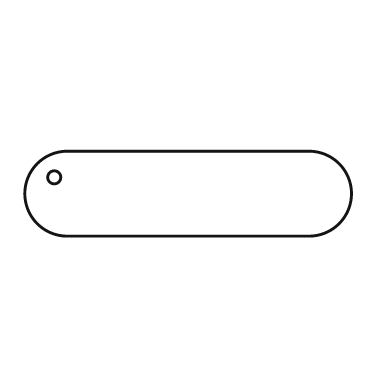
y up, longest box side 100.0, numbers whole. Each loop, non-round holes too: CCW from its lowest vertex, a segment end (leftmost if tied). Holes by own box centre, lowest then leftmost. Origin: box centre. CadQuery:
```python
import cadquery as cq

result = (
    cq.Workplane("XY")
    .moveTo(-37.0, -13.0)
    .lineTo(37.0, -13.0)
    .threePointArc((50.0, 0.0), (37.0, 13.0))
    .lineTo(-37.0, 13.0)
    .threePointArc((-50.0, 0.0), (-37.0, -13.0))
    .close()
    .moveTo(-41.0, 5.0)
    .circle(2.0)
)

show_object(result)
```